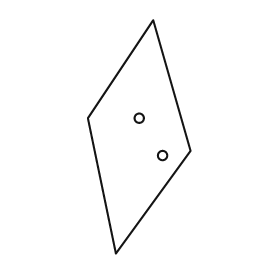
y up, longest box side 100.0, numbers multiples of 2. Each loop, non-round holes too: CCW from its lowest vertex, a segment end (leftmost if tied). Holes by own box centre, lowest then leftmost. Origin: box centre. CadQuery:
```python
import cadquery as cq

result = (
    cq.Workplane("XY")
    .moveTo(-10.0, -50.0)
    .lineTo(22.0, -6.0)
    .lineTo(6.0, 50.0)
    .lineTo(-22.0, 8.0)
    .close()
    .moveTo(10.0, -8.0)
    .circle(2.0)
    .moveTo(0.0, 8.0)
    .circle(2.0)
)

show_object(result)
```